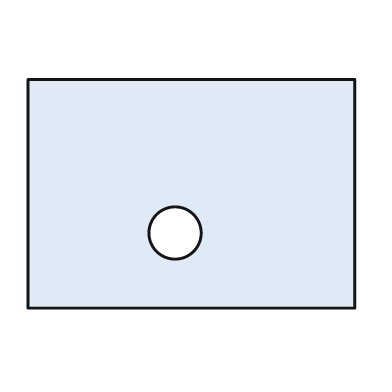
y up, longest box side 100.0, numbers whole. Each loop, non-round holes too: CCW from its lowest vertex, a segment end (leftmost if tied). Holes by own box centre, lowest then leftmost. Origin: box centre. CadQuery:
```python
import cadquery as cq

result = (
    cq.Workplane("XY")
    .moveTo(-50.0, -35.0)
    .lineTo(50.0, -35.0)
    .lineTo(50.0, 35.0)
    .lineTo(-50.0, 35.0)
    .close()
    .moveTo(-5.0, -12.0)
    .circle(8.0)
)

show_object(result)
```